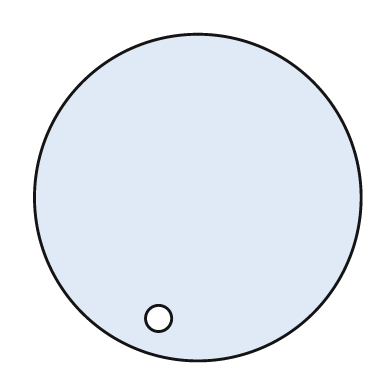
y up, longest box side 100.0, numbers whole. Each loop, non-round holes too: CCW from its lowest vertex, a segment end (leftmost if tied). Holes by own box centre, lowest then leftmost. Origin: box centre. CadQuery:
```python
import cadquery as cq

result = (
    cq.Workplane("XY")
    .moveTo(0.0, 0.0)
    .circle(50.0)
    .moveTo(-12.0, -37.0)
    .circle(4.0)
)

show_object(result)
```